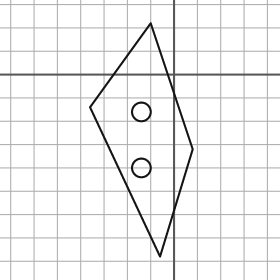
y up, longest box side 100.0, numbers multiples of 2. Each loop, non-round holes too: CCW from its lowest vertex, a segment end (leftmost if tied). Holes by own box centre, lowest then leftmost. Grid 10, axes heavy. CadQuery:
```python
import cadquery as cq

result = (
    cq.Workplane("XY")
    .moveTo(-6.0, -78.0)
    .lineTo(8.0, -32.0)
    .lineTo(-10.0, 22.0)
    .lineTo(-36.0, -14.0)
    .close()
    .moveTo(-14.0, -40.0)
    .circle(4.0)
    .moveTo(-14.0, -16.0)
    .circle(4.0)
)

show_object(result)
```